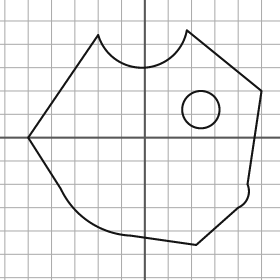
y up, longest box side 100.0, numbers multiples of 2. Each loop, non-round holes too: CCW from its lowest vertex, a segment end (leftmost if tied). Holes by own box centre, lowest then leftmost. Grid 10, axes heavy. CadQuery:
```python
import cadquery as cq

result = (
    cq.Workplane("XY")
    .moveTo(22.0, -46.0)
    .lineTo(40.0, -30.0)
    .threePointArc((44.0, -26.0), (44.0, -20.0))
    .lineTo(50.0, 20.0)
    .lineTo(18.0, 46.0)
    .threePointArc((0.0, 30.0), (-20.0, 44.0))
    .lineTo(-50.0, 0.0)
    .lineTo(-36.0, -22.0)
    .threePointArc((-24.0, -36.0), (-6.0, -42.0))
    .close()
    .moveTo(24.0, 12.0)
    .circle(8.0)
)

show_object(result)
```